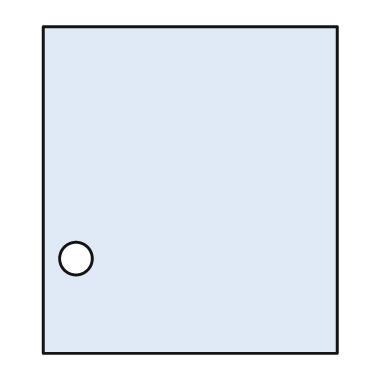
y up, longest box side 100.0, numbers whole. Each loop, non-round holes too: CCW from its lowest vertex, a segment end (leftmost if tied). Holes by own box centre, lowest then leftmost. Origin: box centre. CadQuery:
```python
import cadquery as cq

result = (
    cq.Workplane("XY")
    .moveTo(-45.0, -50.0)
    .lineTo(45.0, -50.0)
    .lineTo(45.0, 50.0)
    .lineTo(-45.0, 50.0)
    .close()
    .moveTo(-35.0, -21.0)
    .circle(5.0)
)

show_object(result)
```